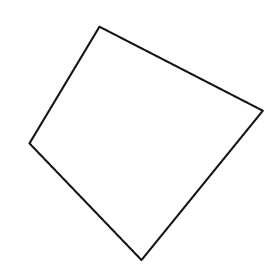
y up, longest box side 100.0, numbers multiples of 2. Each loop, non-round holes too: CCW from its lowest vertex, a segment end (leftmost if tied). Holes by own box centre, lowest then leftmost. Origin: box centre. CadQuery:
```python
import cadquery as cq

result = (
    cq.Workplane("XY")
    .moveTo(-2.0, -50.0)
    .lineTo(50.0, 14.0)
    .lineTo(-20.0, 50.0)
    .lineTo(-50.0, 0.0)
    .close()
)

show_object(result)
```